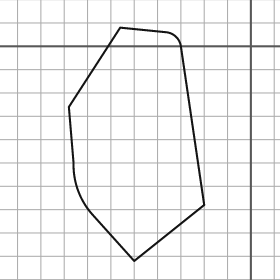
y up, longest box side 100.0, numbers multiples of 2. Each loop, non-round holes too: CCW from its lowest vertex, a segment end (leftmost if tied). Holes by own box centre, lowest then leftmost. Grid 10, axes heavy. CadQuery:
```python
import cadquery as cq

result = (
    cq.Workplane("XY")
    .moveTo(-50.0, -92.0)
    .lineTo(-20.0, -68.0)
    .lineTo(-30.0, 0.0)
    .threePointArc((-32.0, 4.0), (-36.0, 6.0))
    .lineTo(-56.0, 8.0)
    .lineTo(-78.0, -26.0)
    .lineTo(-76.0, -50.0)
    .threePointArc((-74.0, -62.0), (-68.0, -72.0))
    .close()
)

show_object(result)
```